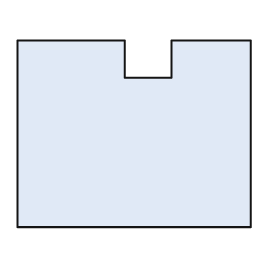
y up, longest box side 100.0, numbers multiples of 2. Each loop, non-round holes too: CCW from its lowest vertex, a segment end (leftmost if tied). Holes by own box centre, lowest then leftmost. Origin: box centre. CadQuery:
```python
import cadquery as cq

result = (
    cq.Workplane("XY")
    .moveTo(-50.0, -40.0)
    .lineTo(50.0, -40.0)
    .lineTo(50.0, 40.0)
    .lineTo(16.0, 40.0)
    .lineTo(16.0, 24.0)
    .lineTo(-4.0, 24.0)
    .lineTo(-4.0, 40.0)
    .lineTo(-50.0, 40.0)
    .close()
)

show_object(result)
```